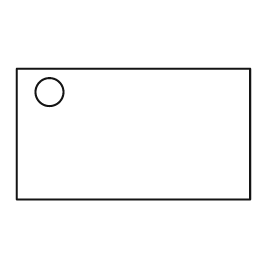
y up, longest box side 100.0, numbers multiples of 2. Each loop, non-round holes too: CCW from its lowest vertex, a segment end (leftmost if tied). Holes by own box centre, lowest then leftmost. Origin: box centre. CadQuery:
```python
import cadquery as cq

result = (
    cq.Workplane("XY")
    .moveTo(-50.0, -28.0)
    .lineTo(50.0, -28.0)
    .lineTo(50.0, 28.0)
    .lineTo(-50.0, 28.0)
    .close()
    .moveTo(-36.0, 18.0)
    .circle(6.0)
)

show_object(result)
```